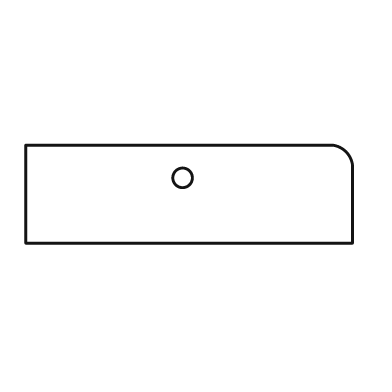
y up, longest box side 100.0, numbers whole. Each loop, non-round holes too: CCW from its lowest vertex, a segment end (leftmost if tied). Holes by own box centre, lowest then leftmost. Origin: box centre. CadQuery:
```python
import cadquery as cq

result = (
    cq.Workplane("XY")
    .moveTo(-50.0, -15.0)
    .lineTo(50.0, -15.0)
    .lineTo(50.0, 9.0)
    .threePointArc((48.0, 13.0), (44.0, 15.0))
    .lineTo(-50.0, 15.0)
    .close()
    .moveTo(-2.0, 5.0)
    .circle(3.0)
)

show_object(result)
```